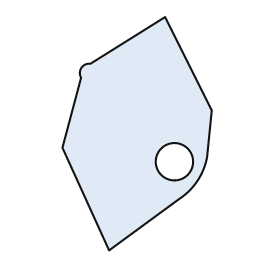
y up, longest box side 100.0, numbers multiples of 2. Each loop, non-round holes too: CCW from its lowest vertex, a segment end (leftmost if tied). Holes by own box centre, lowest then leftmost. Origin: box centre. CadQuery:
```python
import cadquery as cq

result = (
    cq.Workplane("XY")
    .moveTo(-12.0, -50.0)
    .lineTo(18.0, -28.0)
    .threePointArc((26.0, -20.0), (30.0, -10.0))
    .lineTo(32.0, 10.0)
    .lineTo(12.0, 50.0)
    .lineTo(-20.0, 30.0)
    .threePointArc((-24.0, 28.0), (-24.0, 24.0))
    .lineTo(-32.0, -6.0)
    .close()
    .moveTo(16.0, -12.0)
    .circle(8.0)
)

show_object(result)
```